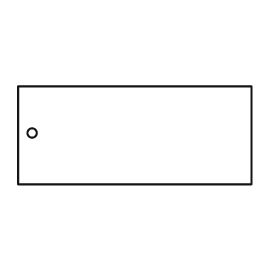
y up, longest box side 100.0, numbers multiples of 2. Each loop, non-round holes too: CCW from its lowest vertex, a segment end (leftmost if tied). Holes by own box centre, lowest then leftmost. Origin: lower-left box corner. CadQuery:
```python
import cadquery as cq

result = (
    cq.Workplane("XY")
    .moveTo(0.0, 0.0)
    .lineTo(100.0, 0.0)
    .lineTo(100.0, 42.0)
    .lineTo(0.0, 42.0)
    .close()
    .moveTo(6.0, 22.0)
    .circle(2.0)
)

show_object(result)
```